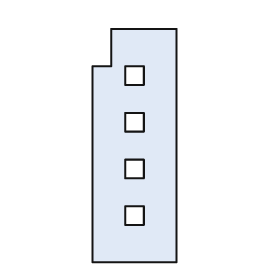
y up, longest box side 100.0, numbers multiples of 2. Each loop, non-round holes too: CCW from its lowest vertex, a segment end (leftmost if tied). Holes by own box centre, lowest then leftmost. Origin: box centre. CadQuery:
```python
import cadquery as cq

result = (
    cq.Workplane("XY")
    .moveTo(-18.0, -50.0)
    .lineTo(18.0, -50.0)
    .lineTo(18.0, 50.0)
    .lineTo(-10.0, 50.0)
    .lineTo(-10.0, 34.0)
    .lineTo(-18.0, 34.0)
    .close()
    .moveTo(-4.0, -34.0)
    .lineTo(4.0, -34.0)
    .lineTo(4.0, -26.0)
    .lineTo(-4.0, -26.0)
    .close()
    .moveTo(-4.0, -14.0)
    .lineTo(4.0, -14.0)
    .lineTo(4.0, -6.0)
    .lineTo(-4.0, -6.0)
    .close()
    .moveTo(-4.0, 6.0)
    .lineTo(4.0, 6.0)
    .lineTo(4.0, 14.0)
    .lineTo(-4.0, 14.0)
    .close()
    .moveTo(-4.0, 26.0)
    .lineTo(4.0, 26.0)
    .lineTo(4.0, 34.0)
    .lineTo(-4.0, 34.0)
    .close()
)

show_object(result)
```